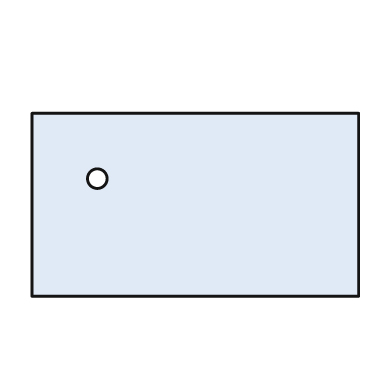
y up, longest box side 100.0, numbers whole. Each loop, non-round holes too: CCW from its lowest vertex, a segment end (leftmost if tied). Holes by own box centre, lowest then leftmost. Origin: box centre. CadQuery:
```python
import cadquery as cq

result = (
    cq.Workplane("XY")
    .moveTo(-50.0, -28.0)
    .lineTo(50.0, -28.0)
    .lineTo(50.0, 28.0)
    .lineTo(-50.0, 28.0)
    .close()
    .moveTo(-30.0, 8.0)
    .circle(3.0)
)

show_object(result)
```